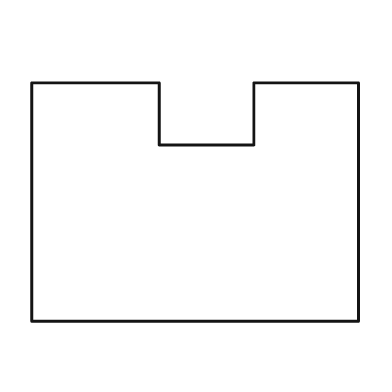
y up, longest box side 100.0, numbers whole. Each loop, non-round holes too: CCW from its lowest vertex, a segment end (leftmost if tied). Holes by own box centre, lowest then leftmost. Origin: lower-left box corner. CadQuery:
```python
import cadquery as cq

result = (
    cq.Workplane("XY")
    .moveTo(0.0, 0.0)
    .lineTo(100.0, 0.0)
    .lineTo(100.0, 73.0)
    .lineTo(68.0, 73.0)
    .lineTo(68.0, 54.0)
    .lineTo(39.0, 54.0)
    .lineTo(39.0, 73.0)
    .lineTo(0.0, 73.0)
    .close()
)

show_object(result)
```